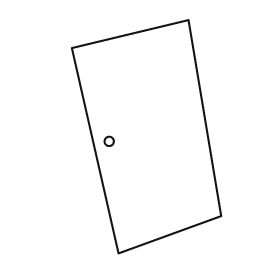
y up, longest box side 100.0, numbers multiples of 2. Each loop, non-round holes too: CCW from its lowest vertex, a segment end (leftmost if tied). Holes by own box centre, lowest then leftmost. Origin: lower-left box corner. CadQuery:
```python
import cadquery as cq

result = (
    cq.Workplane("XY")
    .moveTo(20.0, 0.0)
    .lineTo(64.0, 16.0)
    .lineTo(50.0, 100.0)
    .lineTo(0.0, 88.0)
    .close()
    .moveTo(16.0, 48.0)
    .circle(2.0)
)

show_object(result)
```